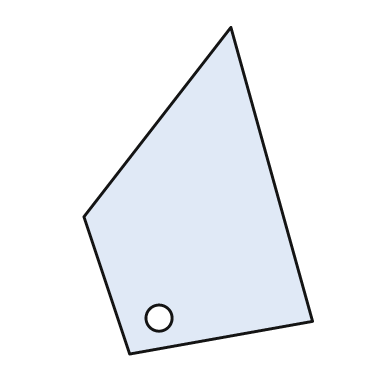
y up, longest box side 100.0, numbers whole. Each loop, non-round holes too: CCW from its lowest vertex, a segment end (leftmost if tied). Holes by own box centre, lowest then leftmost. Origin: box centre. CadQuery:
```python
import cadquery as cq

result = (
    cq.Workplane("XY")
    .moveTo(-21.0, -50.0)
    .lineTo(35.0, -40.0)
    .lineTo(10.0, 50.0)
    .lineTo(-35.0, -8.0)
    .close()
    .moveTo(-12.0, -39.0)
    .circle(4.0)
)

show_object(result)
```